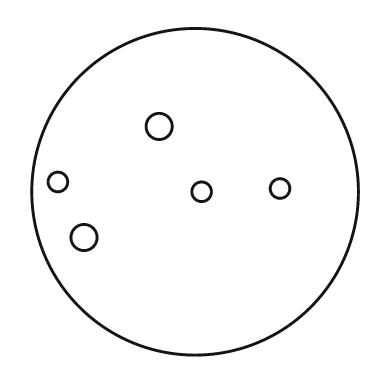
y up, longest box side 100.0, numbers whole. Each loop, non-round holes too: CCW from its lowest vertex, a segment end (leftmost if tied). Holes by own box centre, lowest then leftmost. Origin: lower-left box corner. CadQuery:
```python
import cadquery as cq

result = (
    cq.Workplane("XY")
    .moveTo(50.0, 50.0)
    .circle(50.0)
    .moveTo(16.0, 36.0)
    .circle(4.0)
    .moveTo(52.0, 50.0)
    .circle(3.0)
    .moveTo(76.0, 51.0)
    .circle(3.0)
    .moveTo(8.0, 53.0)
    .circle(3.0)
    .moveTo(39.0, 70.0)
    .circle(4.0)
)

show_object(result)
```